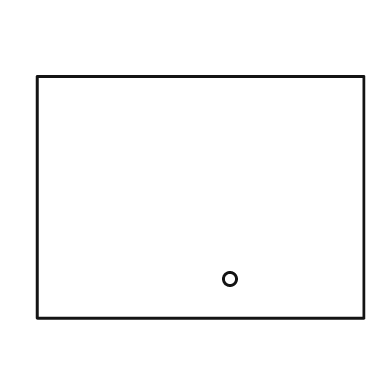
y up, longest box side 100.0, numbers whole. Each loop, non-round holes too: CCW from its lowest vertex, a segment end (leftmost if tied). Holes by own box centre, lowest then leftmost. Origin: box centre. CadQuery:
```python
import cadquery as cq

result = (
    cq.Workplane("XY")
    .moveTo(-50.0, -37.0)
    .lineTo(50.0, -37.0)
    .lineTo(50.0, 37.0)
    .lineTo(-50.0, 37.0)
    .close()
    .moveTo(9.0, -25.0)
    .circle(2.0)
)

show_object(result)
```